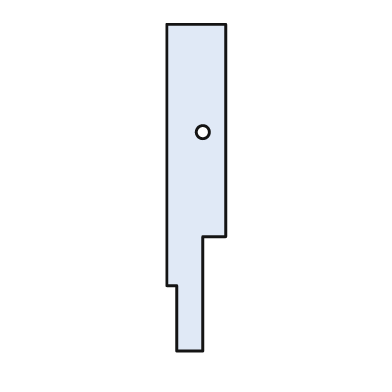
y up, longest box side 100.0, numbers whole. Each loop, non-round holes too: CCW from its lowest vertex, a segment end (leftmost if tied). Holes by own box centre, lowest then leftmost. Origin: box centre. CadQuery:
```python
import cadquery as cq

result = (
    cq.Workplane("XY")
    .moveTo(-6.0, -50.0)
    .lineTo(2.0, -50.0)
    .lineTo(2.0, -15.0)
    .lineTo(9.0, -15.0)
    .lineTo(9.0, 50.0)
    .lineTo(-9.0, 50.0)
    .lineTo(-9.0, -30.0)
    .lineTo(-6.0, -30.0)
    .close()
    .moveTo(2.0, 17.0)
    .circle(2.0)
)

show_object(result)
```